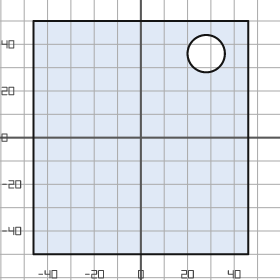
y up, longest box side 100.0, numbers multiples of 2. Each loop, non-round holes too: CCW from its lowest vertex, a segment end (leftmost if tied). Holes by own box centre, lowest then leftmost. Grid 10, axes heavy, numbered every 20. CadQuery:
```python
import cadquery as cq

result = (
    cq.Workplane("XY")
    .moveTo(-46.0, -50.0)
    .lineTo(46.0, -50.0)
    .lineTo(46.0, 50.0)
    .lineTo(-46.0, 50.0)
    .close()
    .moveTo(28.0, 36.0)
    .circle(8.0)
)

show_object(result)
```